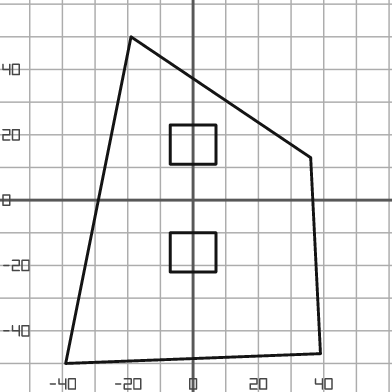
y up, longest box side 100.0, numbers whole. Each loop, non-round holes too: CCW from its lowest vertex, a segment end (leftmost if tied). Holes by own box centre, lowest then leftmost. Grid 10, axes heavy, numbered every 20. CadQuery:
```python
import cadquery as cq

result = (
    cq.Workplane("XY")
    .moveTo(-39.0, -50.0)
    .lineTo(39.0, -47.0)
    .lineTo(36.0, 13.0)
    .lineTo(-19.0, 50.0)
    .close()
    .moveTo(-7.0, -22.0)
    .lineTo(7.0, -22.0)
    .lineTo(7.0, -10.0)
    .lineTo(-7.0, -10.0)
    .close()
    .moveTo(-7.0, 11.0)
    .lineTo(7.0, 11.0)
    .lineTo(7.0, 23.0)
    .lineTo(-7.0, 23.0)
    .close()
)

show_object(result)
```